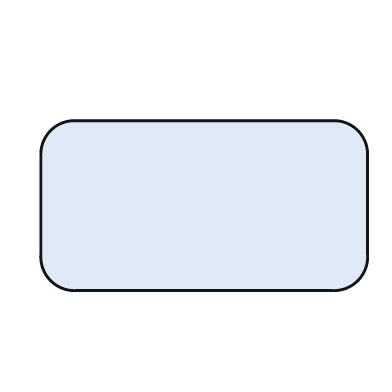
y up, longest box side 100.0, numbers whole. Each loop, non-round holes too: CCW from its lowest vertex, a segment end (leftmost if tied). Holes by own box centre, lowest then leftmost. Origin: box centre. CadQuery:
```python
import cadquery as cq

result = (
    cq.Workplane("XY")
    .moveTo(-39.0, -26.0)
    .lineTo(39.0, -26.0)
    .threePointArc((47.0, -23.0), (50.0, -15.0))
    .lineTo(50.0, 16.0)
    .threePointArc((47.0, 23.0), (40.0, 26.0))
    .lineTo(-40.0, 26.0)
    .threePointArc((-47.0, 23.0), (-50.0, 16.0))
    .lineTo(-50.0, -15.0)
    .threePointArc((-47.0, -23.0), (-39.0, -26.0))
    .close()
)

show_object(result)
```